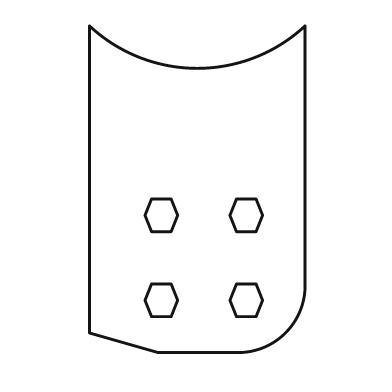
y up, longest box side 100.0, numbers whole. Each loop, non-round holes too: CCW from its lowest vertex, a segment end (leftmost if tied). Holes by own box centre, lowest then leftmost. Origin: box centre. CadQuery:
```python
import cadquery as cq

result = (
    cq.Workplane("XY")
    .moveTo(-12.0, -50.0)
    .lineTo(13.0, -50.0)
    .threePointArc((27.0, -44.0), (33.0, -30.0))
    .lineTo(33.0, 50.0)
    .threePointArc((0.0, 37.0), (-33.0, 50.0))
    .lineTo(-33.0, -44.0)
    .close()
    .moveTo(-14.0, -39.0)
    .lineTo(-8.0, -39.0)
    .lineTo(-6.0, -34.0)
    .lineTo(-8.0, -29.0)
    .lineTo(-14.0, -29.0)
    .lineTo(-16.0, -34.0)
    .close()
    .moveTo(12.0, -39.0)
    .lineTo(18.0, -39.0)
    .lineTo(20.0, -34.0)
    .lineTo(18.0, -29.0)
    .lineTo(12.0, -29.0)
    .lineTo(10.0, -34.0)
    .close()
    .moveTo(-14.0, -13.0)
    .lineTo(-8.0, -13.0)
    .lineTo(-6.0, -8.0)
    .lineTo(-8.0, -3.0)
    .lineTo(-14.0, -3.0)
    .lineTo(-16.0, -8.0)
    .close()
    .moveTo(12.0, -13.0)
    .lineTo(18.0, -13.0)
    .lineTo(20.0, -8.0)
    .lineTo(18.0, -3.0)
    .lineTo(12.0, -3.0)
    .lineTo(10.0, -8.0)
    .close()
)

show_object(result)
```